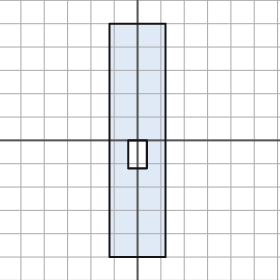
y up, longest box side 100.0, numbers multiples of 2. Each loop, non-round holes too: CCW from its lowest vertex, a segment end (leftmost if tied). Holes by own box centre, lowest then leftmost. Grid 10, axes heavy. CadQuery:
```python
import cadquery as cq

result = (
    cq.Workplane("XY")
    .moveTo(-12.0, -50.0)
    .lineTo(12.0, -50.0)
    .lineTo(12.0, 50.0)
    .lineTo(-12.0, 50.0)
    .close()
    .moveTo(-4.0, -12.0)
    .lineTo(4.0, -12.0)
    .lineTo(4.0, 0.0)
    .lineTo(-4.0, 0.0)
    .close()
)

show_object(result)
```